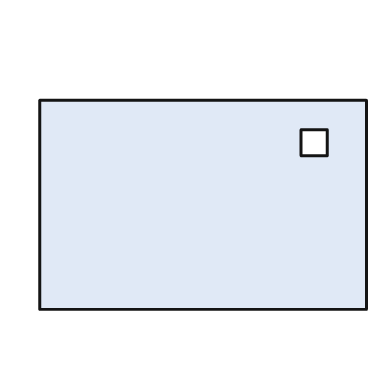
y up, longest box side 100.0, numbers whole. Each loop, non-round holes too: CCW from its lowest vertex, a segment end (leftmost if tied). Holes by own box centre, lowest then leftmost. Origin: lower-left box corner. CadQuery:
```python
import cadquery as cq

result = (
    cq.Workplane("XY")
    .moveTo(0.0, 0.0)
    .lineTo(100.0, 0.0)
    .lineTo(100.0, 64.0)
    .lineTo(0.0, 64.0)
    .close()
    .moveTo(80.0, 47.0)
    .lineTo(88.0, 47.0)
    .lineTo(88.0, 55.0)
    .lineTo(80.0, 55.0)
    .close()
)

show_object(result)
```